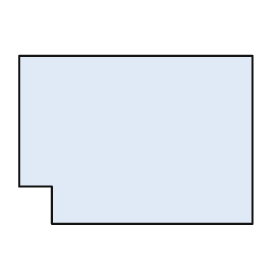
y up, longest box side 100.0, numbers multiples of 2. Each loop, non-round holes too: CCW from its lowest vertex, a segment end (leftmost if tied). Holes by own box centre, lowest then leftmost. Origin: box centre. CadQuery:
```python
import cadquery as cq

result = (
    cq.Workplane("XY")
    .moveTo(-36.0, -36.0)
    .lineTo(50.0, -36.0)
    .lineTo(50.0, 36.0)
    .lineTo(-50.0, 36.0)
    .lineTo(-50.0, -20.0)
    .lineTo(-36.0, -20.0)
    .close()
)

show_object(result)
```